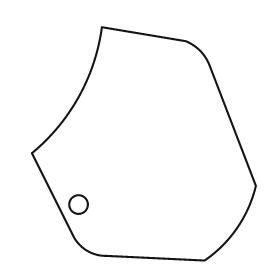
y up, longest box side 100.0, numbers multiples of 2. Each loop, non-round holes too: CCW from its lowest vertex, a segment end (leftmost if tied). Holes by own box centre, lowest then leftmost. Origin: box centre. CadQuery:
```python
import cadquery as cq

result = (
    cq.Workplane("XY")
    .moveTo(26.0, -50.0)
    .threePointArc((40.0, -36.0), (48.0, -18.0))
    .lineTo(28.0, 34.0)
    .threePointArc((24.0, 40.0), (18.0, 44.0))
    .lineTo(-18.0, 50.0)
    .threePointArc((-28.0, 20.0), (-48.0, -4.0))
    .lineTo(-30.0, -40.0)
    .threePointArc((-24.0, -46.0), (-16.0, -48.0))
    .close()
    .moveTo(-28.0, -26.0)
    .circle(4.0)
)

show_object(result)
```